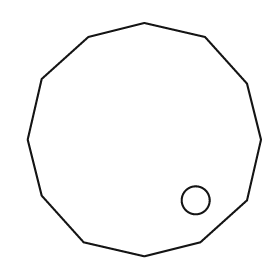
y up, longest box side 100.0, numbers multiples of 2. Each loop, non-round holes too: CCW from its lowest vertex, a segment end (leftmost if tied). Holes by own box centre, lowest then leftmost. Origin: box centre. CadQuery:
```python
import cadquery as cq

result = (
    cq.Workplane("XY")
    .moveTo(0.0, -50.0)
    .lineTo(24.0, -44.0)
    .lineTo(44.0, -26.0)
    .lineTo(50.0, 0.0)
    .lineTo(44.0, 24.0)
    .lineTo(26.0, 44.0)
    .lineTo(0.0, 50.0)
    .lineTo(-24.0, 44.0)
    .lineTo(-44.0, 26.0)
    .lineTo(-50.0, 0.0)
    .lineTo(-44.0, -24.0)
    .lineTo(-26.0, -44.0)
    .close()
    .moveTo(22.0, -26.0)
    .circle(6.0)
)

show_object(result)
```